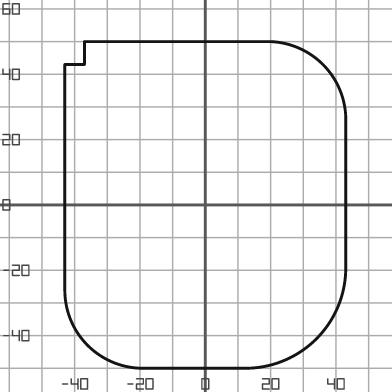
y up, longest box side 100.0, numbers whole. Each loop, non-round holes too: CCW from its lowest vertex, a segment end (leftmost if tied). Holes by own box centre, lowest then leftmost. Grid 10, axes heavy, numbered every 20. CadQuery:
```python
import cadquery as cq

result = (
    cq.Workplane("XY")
    .moveTo(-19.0, -50.0)
    .lineTo(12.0, -50.0)
    .threePointArc((34.0, -41.0), (43.0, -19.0))
    .lineTo(43.0, 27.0)
    .threePointArc((36.0, 43.0), (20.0, 50.0))
    .lineTo(-37.0, 50.0)
    .lineTo(-37.0, 43.0)
    .lineTo(-43.0, 43.0)
    .lineTo(-43.0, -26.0)
    .threePointArc((-36.0, -43.0), (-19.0, -50.0))
    .close()
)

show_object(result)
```